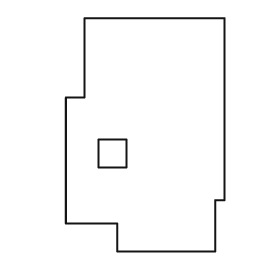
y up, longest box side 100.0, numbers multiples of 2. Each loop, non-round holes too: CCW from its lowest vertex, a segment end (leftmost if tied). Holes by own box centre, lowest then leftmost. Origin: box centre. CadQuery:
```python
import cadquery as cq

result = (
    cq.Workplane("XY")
    .moveTo(-12.0, -50.0)
    .lineTo(30.0, -50.0)
    .lineTo(30.0, -28.0)
    .lineTo(34.0, -28.0)
    .lineTo(34.0, 50.0)
    .lineTo(-26.0, 50.0)
    .lineTo(-26.0, 16.0)
    .lineTo(-34.0, 16.0)
    .lineTo(-34.0, -38.0)
    .lineTo(-12.0, -38.0)
    .close()
    .moveTo(-20.0, -14.0)
    .lineTo(-8.0, -14.0)
    .lineTo(-8.0, -2.0)
    .lineTo(-20.0, -2.0)
    .close()
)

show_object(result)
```